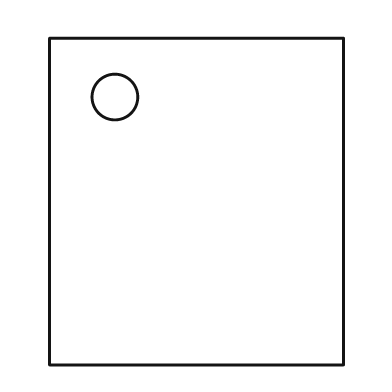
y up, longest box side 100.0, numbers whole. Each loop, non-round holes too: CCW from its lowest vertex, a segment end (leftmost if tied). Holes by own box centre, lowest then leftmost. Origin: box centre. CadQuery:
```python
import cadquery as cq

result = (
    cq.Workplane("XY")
    .moveTo(-45.0, -50.0)
    .lineTo(45.0, -50.0)
    .lineTo(45.0, 50.0)
    .lineTo(-45.0, 50.0)
    .close()
    .moveTo(-25.0, 32.0)
    .circle(7.0)
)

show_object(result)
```